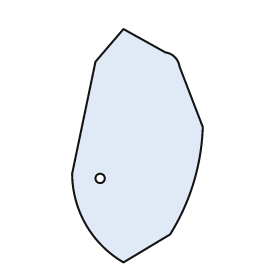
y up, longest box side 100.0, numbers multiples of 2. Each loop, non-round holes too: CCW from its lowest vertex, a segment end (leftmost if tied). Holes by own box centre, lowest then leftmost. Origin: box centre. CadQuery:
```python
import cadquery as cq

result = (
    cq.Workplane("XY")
    .moveTo(-6.0, -50.0)
    .lineTo(14.0, -38.0)
    .threePointArc((24.0, -16.0), (28.0, 8.0))
    .lineTo(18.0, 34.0)
    .threePointArc((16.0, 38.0), (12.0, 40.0))
    .lineTo(-6.0, 50.0)
    .lineTo(-18.0, 36.0)
    .lineTo(-28.0, -12.0)
    .threePointArc((-22.0, -34.0), (-6.0, -50.0))
    .close()
    .moveTo(-16.0, -14.0)
    .circle(2.0)
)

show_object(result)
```